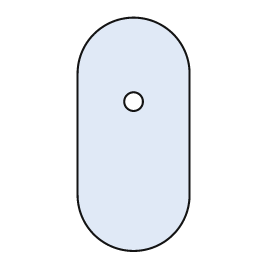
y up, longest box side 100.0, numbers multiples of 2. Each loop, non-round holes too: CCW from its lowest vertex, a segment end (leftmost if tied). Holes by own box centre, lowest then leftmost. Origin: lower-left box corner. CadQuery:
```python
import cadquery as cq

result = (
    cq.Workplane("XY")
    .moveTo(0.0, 24.0)
    .threePointArc((24.0, 0.0), (48.0, 24.0))
    .lineTo(48.0, 76.0)
    .threePointArc((24.0, 100.0), (0.0, 76.0))
    .close()
    .moveTo(24.0, 64.0)
    .circle(4.0)
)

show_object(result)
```